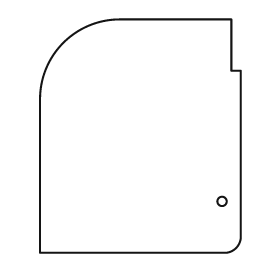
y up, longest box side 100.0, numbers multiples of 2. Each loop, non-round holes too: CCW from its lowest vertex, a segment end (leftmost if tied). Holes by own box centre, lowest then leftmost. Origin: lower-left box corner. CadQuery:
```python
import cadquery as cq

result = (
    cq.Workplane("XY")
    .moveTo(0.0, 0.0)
    .lineTo(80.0, 0.0)
    .threePointArc((84.0, 2.0), (86.0, 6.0))
    .lineTo(86.0, 78.0)
    .lineTo(82.0, 78.0)
    .lineTo(82.0, 100.0)
    .lineTo(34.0, 100.0)
    .threePointArc((10.0, 90.0), (0.0, 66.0))
    .close()
    .moveTo(78.0, 22.0)
    .circle(2.0)
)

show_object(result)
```